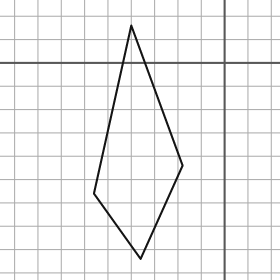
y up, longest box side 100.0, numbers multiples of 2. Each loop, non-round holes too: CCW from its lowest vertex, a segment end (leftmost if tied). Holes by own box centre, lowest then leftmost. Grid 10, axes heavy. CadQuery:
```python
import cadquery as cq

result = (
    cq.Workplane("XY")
    .moveTo(-36.0, -84.0)
    .lineTo(-18.0, -44.0)
    .lineTo(-40.0, 16.0)
    .lineTo(-56.0, -56.0)
    .close()
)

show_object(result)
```